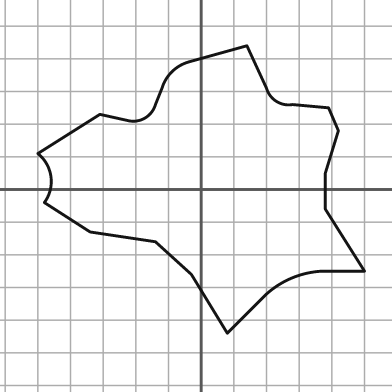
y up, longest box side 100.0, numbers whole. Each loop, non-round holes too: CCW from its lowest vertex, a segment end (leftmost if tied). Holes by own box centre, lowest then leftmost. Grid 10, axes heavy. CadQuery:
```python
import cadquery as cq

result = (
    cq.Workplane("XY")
    .moveTo(8.0, -44.0)
    .lineTo(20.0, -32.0)
    .threePointArc((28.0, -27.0), (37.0, -25.0))
    .lineTo(50.0, -25.0)
    .lineTo(38.0, -6.0)
    .lineTo(38.0, 5.0)
    .lineTo(42.0, 18.0)
    .lineTo(39.0, 25.0)
    .lineTo(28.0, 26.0)
    .threePointArc((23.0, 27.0), (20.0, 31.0))
    .lineTo(14.0, 44.0)
    .lineTo(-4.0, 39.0)
    .threePointArc((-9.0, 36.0), (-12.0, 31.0))
    .lineTo(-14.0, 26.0)
    .threePointArc((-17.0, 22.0), (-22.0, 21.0))
    .lineTo(-31.0, 23.0)
    .lineTo(-50.0, 11.0)
    .threePointArc((-46.0, 4.0), (-48.0, -4.0))
    .lineTo(-34.0, -13.0)
    .lineTo(-14.0, -16.0)
    .lineTo(-3.0, -26.0)
    .close()
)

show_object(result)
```